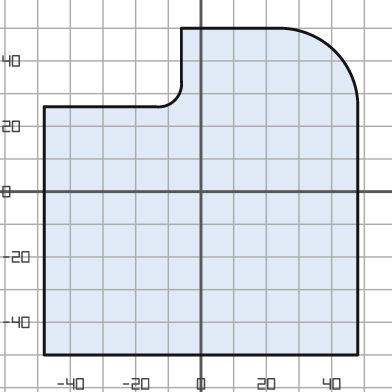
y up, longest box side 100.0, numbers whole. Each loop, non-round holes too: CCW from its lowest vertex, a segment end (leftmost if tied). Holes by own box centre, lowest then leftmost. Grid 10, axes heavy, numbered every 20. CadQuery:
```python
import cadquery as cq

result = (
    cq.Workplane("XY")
    .moveTo(-48.0, -50.0)
    .lineTo(48.0, -50.0)
    .lineTo(48.0, 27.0)
    .threePointArc((41.0, 43.0), (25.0, 50.0))
    .lineTo(-6.0, 50.0)
    .lineTo(-6.0, 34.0)
    .threePointArc((-8.0, 28.0), (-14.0, 26.0))
    .lineTo(-48.0, 26.0)
    .close()
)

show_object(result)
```